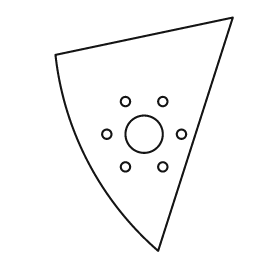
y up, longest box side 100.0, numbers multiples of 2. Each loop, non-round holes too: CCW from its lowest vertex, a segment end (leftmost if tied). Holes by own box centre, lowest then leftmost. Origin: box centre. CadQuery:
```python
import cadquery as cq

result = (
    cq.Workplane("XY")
    .moveTo(6.0, -50.0)
    .lineTo(38.0, 50.0)
    .lineTo(-38.0, 34.0)
    .threePointArc((-24.0, -12.0), (6.0, -50.0))
    .close()
    .moveTo(-8.0, -14.0)
    .circle(2.0)
    .moveTo(8.0, -14.0)
    .circle(2.0)
    .moveTo(-16.0, 0.0)
    .circle(2.0)
    .moveTo(0.0, 0.0)
    .circle(8.0)
    .moveTo(16.0, 0.0)
    .circle(2.0)
    .moveTo(-8.0, 14.0)
    .circle(2.0)
    .moveTo(8.0, 14.0)
    .circle(2.0)
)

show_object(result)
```